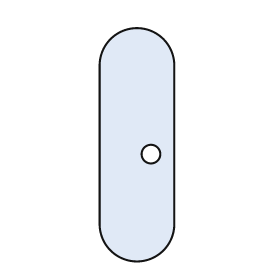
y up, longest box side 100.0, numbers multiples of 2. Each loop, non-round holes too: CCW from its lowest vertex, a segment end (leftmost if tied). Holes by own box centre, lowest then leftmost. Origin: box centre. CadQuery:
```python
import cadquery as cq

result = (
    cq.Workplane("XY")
    .moveTo(-16.0, -34.0)
    .threePointArc((0.0, -50.0), (16.0, -34.0))
    .lineTo(16.0, 34.0)
    .threePointArc((0.0, 50.0), (-16.0, 34.0))
    .close()
    .moveTo(6.0, -4.0)
    .circle(4.0)
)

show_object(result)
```